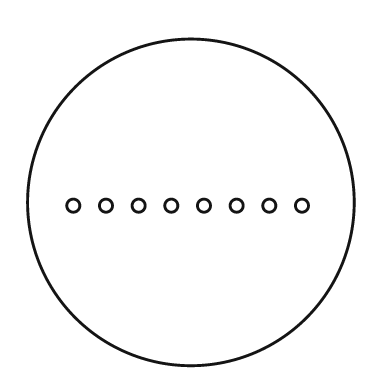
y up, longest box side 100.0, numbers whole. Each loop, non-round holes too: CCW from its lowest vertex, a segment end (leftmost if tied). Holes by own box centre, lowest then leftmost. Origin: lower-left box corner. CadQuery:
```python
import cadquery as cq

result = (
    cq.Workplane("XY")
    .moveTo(50.0, 50.0)
    .circle(50.0)
    .moveTo(14.0, 49.0)
    .circle(2.0)
    .moveTo(24.0, 49.0)
    .circle(2.0)
    .moveTo(34.0, 49.0)
    .circle(2.0)
    .moveTo(44.0, 49.0)
    .circle(2.0)
    .moveTo(54.0, 49.0)
    .circle(2.0)
    .moveTo(64.0, 49.0)
    .circle(2.0)
    .moveTo(74.0, 49.0)
    .circle(2.0)
    .moveTo(84.0, 49.0)
    .circle(2.0)
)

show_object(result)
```